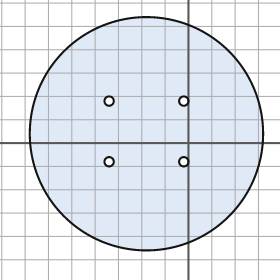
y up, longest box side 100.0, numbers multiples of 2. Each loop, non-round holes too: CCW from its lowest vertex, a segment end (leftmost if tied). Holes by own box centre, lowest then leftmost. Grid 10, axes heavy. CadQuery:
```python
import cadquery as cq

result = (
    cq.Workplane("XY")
    .moveTo(-18.0, 4.0)
    .circle(50.0)
    .moveTo(-34.0, -8.0)
    .circle(2.0)
    .moveTo(-2.0, -8.0)
    .circle(2.0)
    .moveTo(-34.0, 18.0)
    .circle(2.0)
    .moveTo(-2.0, 18.0)
    .circle(2.0)
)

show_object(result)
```